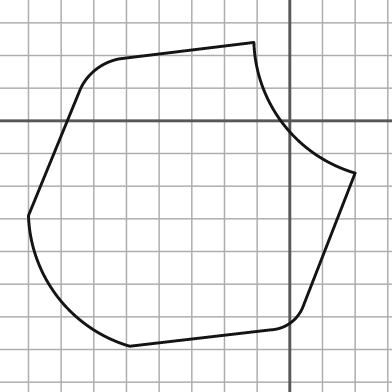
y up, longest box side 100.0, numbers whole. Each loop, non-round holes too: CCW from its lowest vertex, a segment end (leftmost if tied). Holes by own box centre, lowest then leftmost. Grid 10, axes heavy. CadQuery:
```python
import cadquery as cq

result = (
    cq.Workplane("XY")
    .moveTo(-49.0, -69.0)
    .lineTo(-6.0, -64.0)
    .threePointArc((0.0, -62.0), (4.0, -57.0))
    .lineTo(20.0, -16.0)
    .threePointArc((-2.0, -1.0), (-11.0, 24.0))
    .lineTo(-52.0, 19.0)
    .threePointArc((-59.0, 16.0), (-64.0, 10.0))
    .lineTo(-80.0, -29.0)
    .threePointArc((-71.0, -54.0), (-49.0, -69.0))
    .close()
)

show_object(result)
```